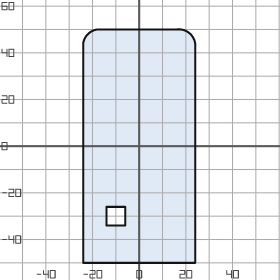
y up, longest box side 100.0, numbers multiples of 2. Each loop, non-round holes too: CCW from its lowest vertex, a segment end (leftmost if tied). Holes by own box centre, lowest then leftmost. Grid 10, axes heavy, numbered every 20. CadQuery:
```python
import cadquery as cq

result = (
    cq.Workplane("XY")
    .moveTo(-24.0, -50.0)
    .lineTo(24.0, -50.0)
    .lineTo(24.0, 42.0)
    .threePointArc((22.0, 48.0), (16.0, 50.0))
    .lineTo(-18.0, 50.0)
    .threePointArc((-22.0, 48.0), (-24.0, 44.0))
    .close()
    .moveTo(-14.0, -34.0)
    .lineTo(-6.0, -34.0)
    .lineTo(-6.0, -26.0)
    .lineTo(-14.0, -26.0)
    .close()
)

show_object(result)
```